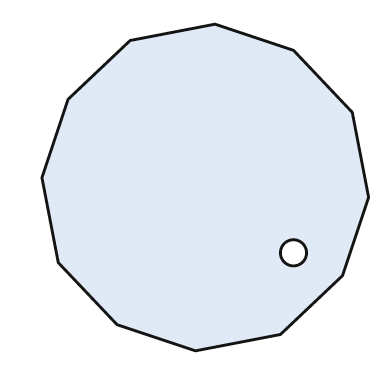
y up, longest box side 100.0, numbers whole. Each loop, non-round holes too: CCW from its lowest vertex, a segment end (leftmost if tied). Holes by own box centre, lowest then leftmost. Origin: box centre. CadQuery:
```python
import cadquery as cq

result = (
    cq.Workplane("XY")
    .moveTo(-3.0, -50.0)
    .lineTo(23.0, -45.0)
    .lineTo(42.0, -27.0)
    .lineTo(50.0, -3.0)
    .lineTo(45.0, 23.0)
    .lineTo(27.0, 42.0)
    .lineTo(3.0, 50.0)
    .lineTo(-23.0, 45.0)
    .lineTo(-42.0, 27.0)
    .lineTo(-50.0, 3.0)
    .lineTo(-45.0, -23.0)
    .lineTo(-27.0, -42.0)
    .close()
    .moveTo(27.0, -20.0)
    .circle(4.0)
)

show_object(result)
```